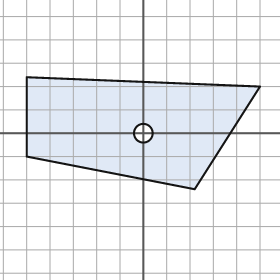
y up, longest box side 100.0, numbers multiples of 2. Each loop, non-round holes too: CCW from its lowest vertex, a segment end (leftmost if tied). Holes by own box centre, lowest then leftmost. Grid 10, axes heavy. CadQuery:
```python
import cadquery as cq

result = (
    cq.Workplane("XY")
    .moveTo(22.0, -24.0)
    .lineTo(50.0, 20.0)
    .lineTo(-50.0, 24.0)
    .lineTo(-50.0, -10.0)
    .close()
    .moveTo(0.0, 0.0)
    .circle(4.0)
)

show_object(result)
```